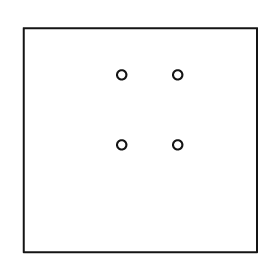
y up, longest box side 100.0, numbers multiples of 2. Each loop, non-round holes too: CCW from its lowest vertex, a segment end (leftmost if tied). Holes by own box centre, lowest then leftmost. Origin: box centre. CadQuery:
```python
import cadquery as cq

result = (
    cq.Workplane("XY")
    .moveTo(-50.0, -48.0)
    .lineTo(50.0, -48.0)
    .lineTo(50.0, 48.0)
    .lineTo(-50.0, 48.0)
    .close()
    .moveTo(-8.0, -2.0)
    .circle(2.0)
    .moveTo(16.0, -2.0)
    .circle(2.0)
    .moveTo(-8.0, 28.0)
    .circle(2.0)
    .moveTo(16.0, 28.0)
    .circle(2.0)
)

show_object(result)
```